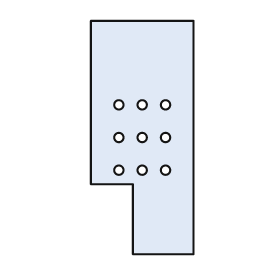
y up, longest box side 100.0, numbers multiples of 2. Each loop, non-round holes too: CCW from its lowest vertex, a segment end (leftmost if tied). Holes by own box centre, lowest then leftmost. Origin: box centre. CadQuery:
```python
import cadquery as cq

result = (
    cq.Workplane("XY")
    .moveTo(-4.0, -50.0)
    .lineTo(22.0, -50.0)
    .lineTo(22.0, 50.0)
    .lineTo(-22.0, 50.0)
    .lineTo(-22.0, -20.0)
    .lineTo(-4.0, -20.0)
    .close()
    .moveTo(-10.0, -14.0)
    .circle(2.0)
    .moveTo(0.0, -14.0)
    .circle(2.0)
    .moveTo(10.0, -14.0)
    .circle(2.0)
    .moveTo(-10.0, 0.0)
    .circle(2.0)
    .moveTo(0.0, 0.0)
    .circle(2.0)
    .moveTo(10.0, 0.0)
    .circle(2.0)
    .moveTo(-10.0, 14.0)
    .circle(2.0)
    .moveTo(0.0, 14.0)
    .circle(2.0)
    .moveTo(10.0, 14.0)
    .circle(2.0)
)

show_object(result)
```